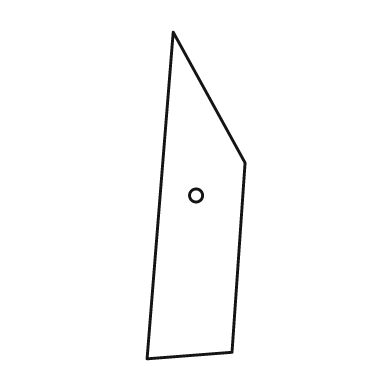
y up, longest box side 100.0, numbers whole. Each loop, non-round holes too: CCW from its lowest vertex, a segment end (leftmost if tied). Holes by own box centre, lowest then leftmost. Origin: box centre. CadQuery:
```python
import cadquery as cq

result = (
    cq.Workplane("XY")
    .moveTo(-15.0, -50.0)
    .lineTo(11.0, -48.0)
    .lineTo(15.0, 10.0)
    .lineTo(-7.0, 50.0)
    .close()
    .moveTo(0.0, 0.0)
    .circle(2.0)
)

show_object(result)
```